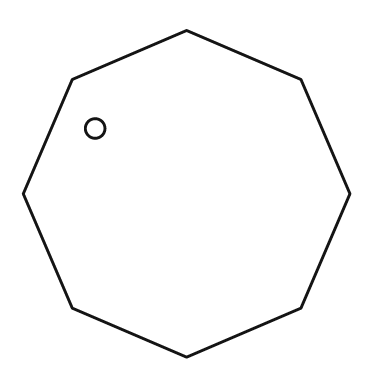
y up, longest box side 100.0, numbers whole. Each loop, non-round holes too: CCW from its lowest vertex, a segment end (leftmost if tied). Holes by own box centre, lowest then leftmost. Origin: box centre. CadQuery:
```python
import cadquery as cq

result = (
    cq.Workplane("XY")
    .moveTo(0.0, -50.0)
    .lineTo(35.0, -35.0)
    .lineTo(50.0, 0.0)
    .lineTo(35.0, 35.0)
    .lineTo(0.0, 50.0)
    .lineTo(-35.0, 35.0)
    .lineTo(-50.0, 0.0)
    .lineTo(-35.0, -35.0)
    .close()
    .moveTo(-28.0, 20.0)
    .circle(3.0)
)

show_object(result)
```